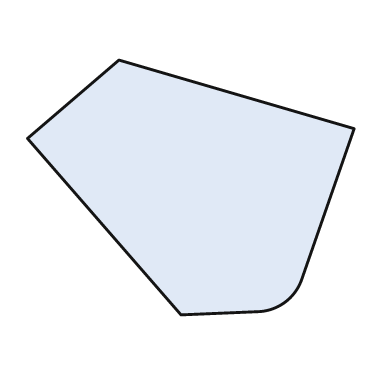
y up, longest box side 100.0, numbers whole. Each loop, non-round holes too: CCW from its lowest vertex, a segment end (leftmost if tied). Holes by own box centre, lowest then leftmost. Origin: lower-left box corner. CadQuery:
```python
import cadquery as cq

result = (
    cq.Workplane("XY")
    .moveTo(47.0, 0.0)
    .lineTo(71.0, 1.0)
    .threePointArc((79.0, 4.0), (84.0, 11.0))
    .lineTo(100.0, 57.0)
    .lineTo(28.0, 78.0)
    .lineTo(0.0, 54.0)
    .close()
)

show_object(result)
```